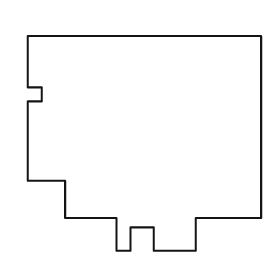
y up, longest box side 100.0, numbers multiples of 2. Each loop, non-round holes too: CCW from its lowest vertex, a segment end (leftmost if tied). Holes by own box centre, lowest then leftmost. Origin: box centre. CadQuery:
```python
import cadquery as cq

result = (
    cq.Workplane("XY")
    .moveTo(-12.0, -46.0)
    .lineTo(-6.0, -46.0)
    .lineTo(-6.0, -36.0)
    .lineTo(4.0, -36.0)
    .lineTo(4.0, -46.0)
    .lineTo(22.0, -46.0)
    .lineTo(22.0, -32.0)
    .lineTo(50.0, -32.0)
    .lineTo(50.0, 46.0)
    .lineTo(-50.0, 46.0)
    .lineTo(-50.0, 24.0)
    .lineTo(-44.0, 24.0)
    .lineTo(-44.0, 18.0)
    .lineTo(-50.0, 18.0)
    .lineTo(-50.0, -16.0)
    .lineTo(-34.0, -16.0)
    .lineTo(-34.0, -32.0)
    .lineTo(-12.0, -32.0)
    .close()
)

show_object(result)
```